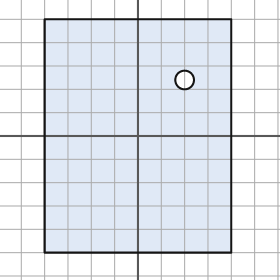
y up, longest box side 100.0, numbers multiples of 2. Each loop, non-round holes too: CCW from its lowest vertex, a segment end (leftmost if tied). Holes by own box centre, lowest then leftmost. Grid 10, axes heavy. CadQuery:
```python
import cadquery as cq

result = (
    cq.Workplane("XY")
    .moveTo(-40.0, -50.0)
    .lineTo(40.0, -50.0)
    .lineTo(40.0, 50.0)
    .lineTo(-40.0, 50.0)
    .close()
    .moveTo(20.0, 24.0)
    .circle(4.0)
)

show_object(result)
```